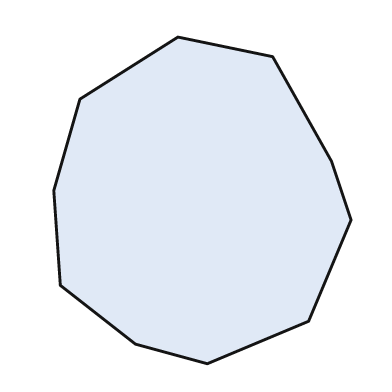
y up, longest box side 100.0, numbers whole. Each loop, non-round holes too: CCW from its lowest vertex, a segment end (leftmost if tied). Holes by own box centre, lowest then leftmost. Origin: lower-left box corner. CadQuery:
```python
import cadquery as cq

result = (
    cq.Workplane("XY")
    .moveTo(47.0, 0.0)
    .lineTo(78.0, 13.0)
    .lineTo(91.0, 44.0)
    .lineTo(85.0, 62.0)
    .lineTo(67.0, 94.0)
    .lineTo(38.0, 100.0)
    .lineTo(8.0, 81.0)
    .lineTo(0.0, 53.0)
    .lineTo(2.0, 24.0)
    .lineTo(25.0, 6.0)
    .close()
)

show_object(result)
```